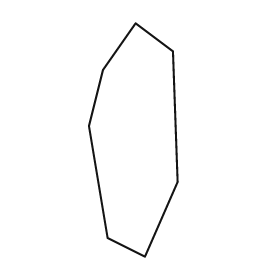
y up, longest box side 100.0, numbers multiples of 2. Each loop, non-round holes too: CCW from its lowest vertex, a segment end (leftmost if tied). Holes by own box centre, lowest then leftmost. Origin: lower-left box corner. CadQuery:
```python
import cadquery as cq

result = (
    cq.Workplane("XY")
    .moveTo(24.0, 0.0)
    .lineTo(38.0, 32.0)
    .lineTo(36.0, 88.0)
    .lineTo(20.0, 100.0)
    .lineTo(6.0, 80.0)
    .lineTo(0.0, 56.0)
    .lineTo(8.0, 8.0)
    .close()
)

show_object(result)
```